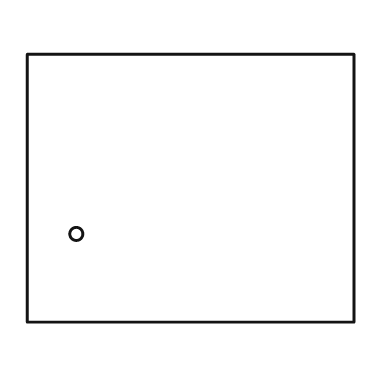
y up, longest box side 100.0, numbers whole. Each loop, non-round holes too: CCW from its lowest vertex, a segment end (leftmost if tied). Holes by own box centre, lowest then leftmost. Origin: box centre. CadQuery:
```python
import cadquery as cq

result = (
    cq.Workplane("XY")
    .moveTo(-50.0, -41.0)
    .lineTo(50.0, -41.0)
    .lineTo(50.0, 41.0)
    .lineTo(-50.0, 41.0)
    .close()
    .moveTo(-35.0, -14.0)
    .circle(2.0)
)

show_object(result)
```